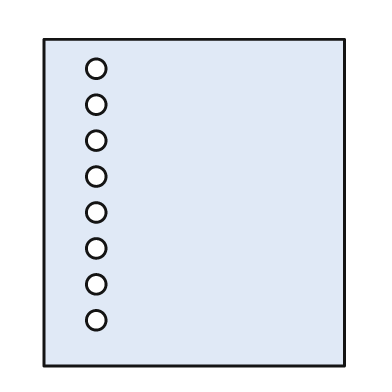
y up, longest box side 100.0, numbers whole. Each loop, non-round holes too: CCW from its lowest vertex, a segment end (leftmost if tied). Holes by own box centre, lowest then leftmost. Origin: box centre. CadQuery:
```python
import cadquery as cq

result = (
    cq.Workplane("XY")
    .moveTo(-46.0, -50.0)
    .lineTo(46.0, -50.0)
    .lineTo(46.0, 50.0)
    .lineTo(-46.0, 50.0)
    .close()
    .moveTo(-30.0, -36.0)
    .circle(3.0)
    .moveTo(-30.0, -25.0)
    .circle(3.0)
    .moveTo(-30.0, -14.0)
    .circle(3.0)
    .moveTo(-30.0, -3.0)
    .circle(3.0)
    .moveTo(-30.0, 8.0)
    .circle(3.0)
    .moveTo(-30.0, 19.0)
    .circle(3.0)
    .moveTo(-30.0, 30.0)
    .circle(3.0)
    .moveTo(-30.0, 41.0)
    .circle(3.0)
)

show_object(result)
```